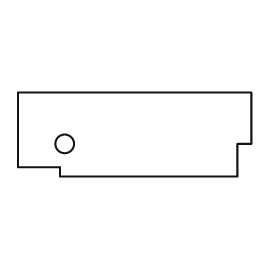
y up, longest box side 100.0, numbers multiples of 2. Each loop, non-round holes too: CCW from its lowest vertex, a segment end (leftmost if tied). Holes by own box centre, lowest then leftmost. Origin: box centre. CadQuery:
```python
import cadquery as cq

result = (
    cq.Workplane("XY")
    .moveTo(-32.0, -18.0)
    .lineTo(44.0, -18.0)
    .lineTo(44.0, -4.0)
    .lineTo(50.0, -4.0)
    .lineTo(50.0, 18.0)
    .lineTo(-50.0, 18.0)
    .lineTo(-50.0, -14.0)
    .lineTo(-32.0, -14.0)
    .close()
    .moveTo(-30.0, -4.0)
    .circle(4.0)
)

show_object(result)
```